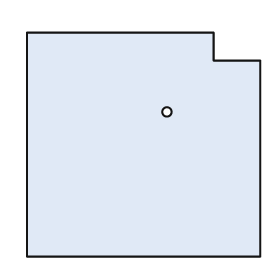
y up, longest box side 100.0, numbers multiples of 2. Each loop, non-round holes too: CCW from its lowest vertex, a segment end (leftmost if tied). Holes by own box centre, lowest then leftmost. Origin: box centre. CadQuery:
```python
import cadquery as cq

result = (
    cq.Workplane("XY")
    .moveTo(-50.0, -48.0)
    .lineTo(50.0, -48.0)
    .lineTo(50.0, 36.0)
    .lineTo(30.0, 36.0)
    .lineTo(30.0, 48.0)
    .lineTo(-50.0, 48.0)
    .close()
    .moveTo(10.0, 14.0)
    .circle(2.0)
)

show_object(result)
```